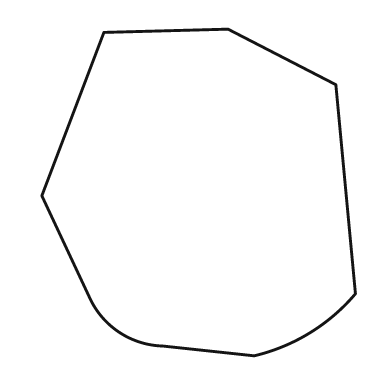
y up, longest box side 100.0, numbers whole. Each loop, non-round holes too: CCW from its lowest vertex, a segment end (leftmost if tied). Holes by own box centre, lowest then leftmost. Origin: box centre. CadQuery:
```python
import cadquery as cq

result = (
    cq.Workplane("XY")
    .moveTo(17.0, -50.0)
    .threePointArc((34.0, -43.0), (48.0, -31.0))
    .lineTo(42.0, 33.0)
    .lineTo(9.0, 50.0)
    .lineTo(-29.0, 49.0)
    .lineTo(-48.0, -1.0)
    .lineTo(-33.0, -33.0)
    .threePointArc((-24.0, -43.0), (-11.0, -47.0))
    .close()
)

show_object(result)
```